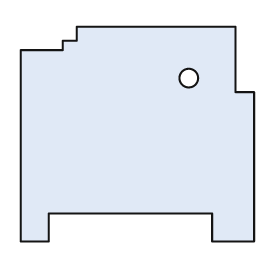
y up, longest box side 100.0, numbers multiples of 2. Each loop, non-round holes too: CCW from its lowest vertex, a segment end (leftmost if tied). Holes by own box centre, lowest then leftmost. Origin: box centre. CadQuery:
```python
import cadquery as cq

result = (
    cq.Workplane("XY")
    .moveTo(-50.0, -46.0)
    .lineTo(-38.0, -46.0)
    .lineTo(-38.0, -34.0)
    .lineTo(32.0, -34.0)
    .lineTo(32.0, -46.0)
    .lineTo(50.0, -46.0)
    .lineTo(50.0, 18.0)
    .lineTo(42.0, 18.0)
    .lineTo(42.0, 46.0)
    .lineTo(-26.0, 46.0)
    .lineTo(-26.0, 40.0)
    .lineTo(-32.0, 40.0)
    .lineTo(-32.0, 36.0)
    .lineTo(-50.0, 36.0)
    .close()
    .moveTo(22.0, 24.0)
    .circle(4.0)
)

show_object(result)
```